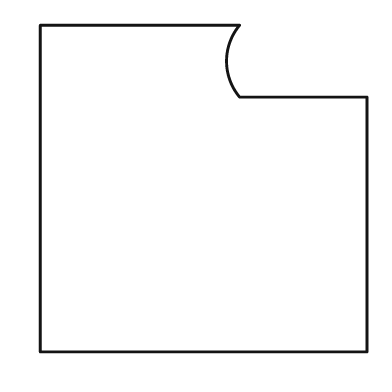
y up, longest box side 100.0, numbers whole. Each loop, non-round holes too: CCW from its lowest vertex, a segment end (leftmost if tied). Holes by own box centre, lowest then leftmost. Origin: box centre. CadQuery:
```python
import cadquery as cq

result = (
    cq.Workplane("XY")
    .moveTo(-50.0, -50.0)
    .lineTo(50.0, -50.0)
    .lineTo(50.0, 28.0)
    .lineTo(11.0, 28.0)
    .threePointArc((7.0, 39.0), (11.0, 50.0))
    .lineTo(-50.0, 50.0)
    .close()
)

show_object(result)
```